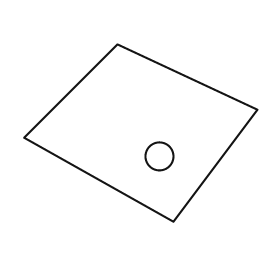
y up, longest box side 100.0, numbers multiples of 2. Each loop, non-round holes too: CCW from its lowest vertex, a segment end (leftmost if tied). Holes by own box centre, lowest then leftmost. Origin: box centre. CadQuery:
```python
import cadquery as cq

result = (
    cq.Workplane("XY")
    .moveTo(14.0, -38.0)
    .lineTo(50.0, 10.0)
    .lineTo(-10.0, 38.0)
    .lineTo(-50.0, -2.0)
    .close()
    .moveTo(8.0, -10.0)
    .circle(6.0)
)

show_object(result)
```